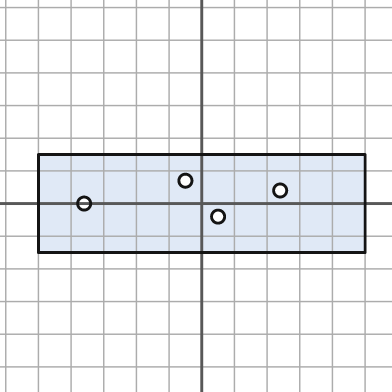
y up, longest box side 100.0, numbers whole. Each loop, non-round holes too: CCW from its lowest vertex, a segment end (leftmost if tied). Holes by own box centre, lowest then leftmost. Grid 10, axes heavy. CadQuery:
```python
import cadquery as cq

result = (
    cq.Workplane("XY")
    .moveTo(-50.0, -15.0)
    .lineTo(50.0, -15.0)
    .lineTo(50.0, 15.0)
    .lineTo(-50.0, 15.0)
    .close()
    .moveTo(5.0, -4.0)
    .circle(2.0)
    .moveTo(-36.0, 0.0)
    .circle(2.0)
    .moveTo(24.0, 4.0)
    .circle(2.0)
    .moveTo(-5.0, 7.0)
    .circle(2.0)
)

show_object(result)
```